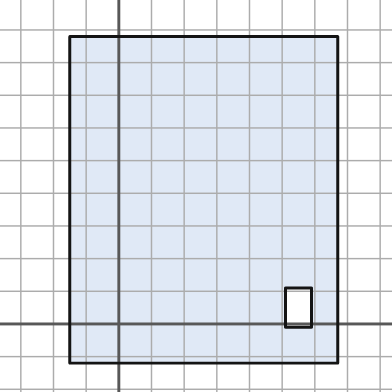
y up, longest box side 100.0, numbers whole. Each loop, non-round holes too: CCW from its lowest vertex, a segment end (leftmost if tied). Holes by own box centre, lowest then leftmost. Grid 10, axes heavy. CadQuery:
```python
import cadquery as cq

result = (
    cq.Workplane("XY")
    .moveTo(-15.0, -12.0)
    .lineTo(67.0, -12.0)
    .lineTo(67.0, 88.0)
    .lineTo(-15.0, 88.0)
    .close()
    .moveTo(51.0, -1.0)
    .lineTo(59.0, -1.0)
    .lineTo(59.0, 11.0)
    .lineTo(51.0, 11.0)
    .close()
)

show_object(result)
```